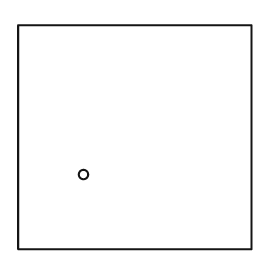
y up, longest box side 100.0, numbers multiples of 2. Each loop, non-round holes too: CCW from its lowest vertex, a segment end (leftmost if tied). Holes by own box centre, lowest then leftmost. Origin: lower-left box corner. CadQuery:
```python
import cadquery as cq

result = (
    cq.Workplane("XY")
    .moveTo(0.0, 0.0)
    .lineTo(100.0, 0.0)
    .lineTo(100.0, 96.0)
    .lineTo(0.0, 96.0)
    .close()
    .moveTo(28.0, 32.0)
    .circle(2.0)
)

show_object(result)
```